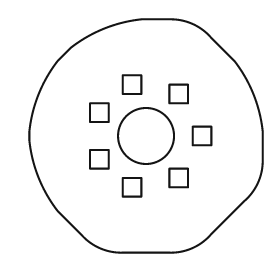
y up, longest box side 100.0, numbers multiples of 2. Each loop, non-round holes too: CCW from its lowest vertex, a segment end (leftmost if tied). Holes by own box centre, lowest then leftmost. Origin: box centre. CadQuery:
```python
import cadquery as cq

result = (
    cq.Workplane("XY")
    .moveTo(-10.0, -50.0)
    .lineTo(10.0, -50.0)
    .threePointArc((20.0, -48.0), (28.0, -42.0))
    .lineTo(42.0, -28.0)
    .threePointArc((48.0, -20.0), (50.0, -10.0))
    .lineTo(50.0, 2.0)
    .threePointArc((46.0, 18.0), (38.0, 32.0))
    .lineTo(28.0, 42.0)
    .threePointArc((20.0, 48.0), (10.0, 50.0))
    .lineTo(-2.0, 50.0)
    .threePointArc((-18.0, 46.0), (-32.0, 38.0))
    .lineTo(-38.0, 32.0)
    .threePointArc((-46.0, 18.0), (-50.0, 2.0))
    .lineTo(-50.0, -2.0)
    .threePointArc((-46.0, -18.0), (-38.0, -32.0))
    .lineTo(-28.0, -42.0)
    .threePointArc((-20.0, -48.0), (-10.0, -50.0))
    .close()
    .moveTo(-10.0, -26.0)
    .lineTo(-2.0, -26.0)
    .lineTo(-2.0, -18.0)
    .lineTo(-10.0, -18.0)
    .close()
    .moveTo(10.0, -22.0)
    .lineTo(18.0, -22.0)
    .lineTo(18.0, -14.0)
    .lineTo(10.0, -14.0)
    .close()
    .moveTo(-24.0, -14.0)
    .lineTo(-16.0, -14.0)
    .lineTo(-16.0, -6.0)
    .lineTo(-24.0, -6.0)
    .close()
    .moveTo(0.0, 0.0)
    .circle(12.0)
    .moveTo(20.0, -4.0)
    .lineTo(28.0, -4.0)
    .lineTo(28.0, 4.0)
    .lineTo(20.0, 4.0)
    .close()
    .moveTo(-24.0, 6.0)
    .lineTo(-16.0, 6.0)
    .lineTo(-16.0, 14.0)
    .lineTo(-24.0, 14.0)
    .close()
    .moveTo(10.0, 14.0)
    .lineTo(18.0, 14.0)
    .lineTo(18.0, 22.0)
    .lineTo(10.0, 22.0)
    .close()
    .moveTo(-10.0, 18.0)
    .lineTo(-2.0, 18.0)
    .lineTo(-2.0, 26.0)
    .lineTo(-10.0, 26.0)
    .close()
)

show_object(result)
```